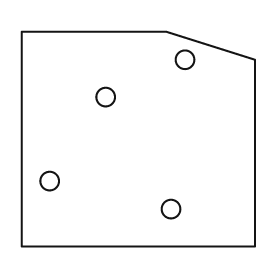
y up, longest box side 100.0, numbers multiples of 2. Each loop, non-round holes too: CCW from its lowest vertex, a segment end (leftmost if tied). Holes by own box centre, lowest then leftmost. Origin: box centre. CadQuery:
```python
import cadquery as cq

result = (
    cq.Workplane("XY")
    .moveTo(-50.0, -46.0)
    .lineTo(50.0, -46.0)
    .lineTo(50.0, 34.0)
    .lineTo(12.0, 46.0)
    .lineTo(-50.0, 46.0)
    .close()
    .moveTo(14.0, -30.0)
    .circle(4.0)
    .moveTo(-38.0, -18.0)
    .circle(4.0)
    .moveTo(-14.0, 18.0)
    .circle(4.0)
    .moveTo(20.0, 34.0)
    .circle(4.0)
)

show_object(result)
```